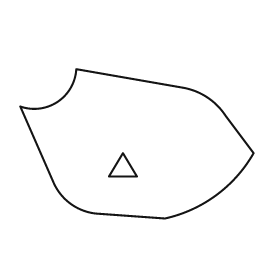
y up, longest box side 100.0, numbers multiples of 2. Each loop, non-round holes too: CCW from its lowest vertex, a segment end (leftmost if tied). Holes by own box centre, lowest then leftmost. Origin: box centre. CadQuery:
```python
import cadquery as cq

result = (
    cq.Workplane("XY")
    .moveTo(12.0, -32.0)
    .threePointArc((34.0, -22.0), (50.0, -4.0))
    .lineTo(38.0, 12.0)
    .threePointArc((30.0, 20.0), (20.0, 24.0))
    .lineTo(-26.0, 32.0)
    .threePointArc((-34.0, 18.0), (-50.0, 16.0))
    .lineTo(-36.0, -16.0)
    .threePointArc((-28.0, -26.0), (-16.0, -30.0))
    .close()
    .moveTo(-12.0, -14.0)
    .lineTo(0.0, -14.0)
    .lineTo(-6.0, -4.0)
    .close()
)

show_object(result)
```